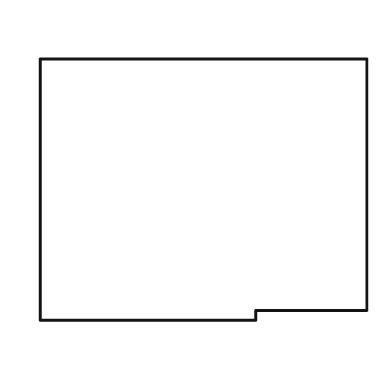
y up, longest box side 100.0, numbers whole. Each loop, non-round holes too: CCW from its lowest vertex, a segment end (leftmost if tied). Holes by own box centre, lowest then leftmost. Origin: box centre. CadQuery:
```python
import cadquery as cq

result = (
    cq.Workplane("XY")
    .moveTo(-50.0, -40.0)
    .lineTo(16.0, -40.0)
    .lineTo(16.0, -37.0)
    .lineTo(50.0, -37.0)
    .lineTo(50.0, 40.0)
    .lineTo(-50.0, 40.0)
    .close()
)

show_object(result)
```